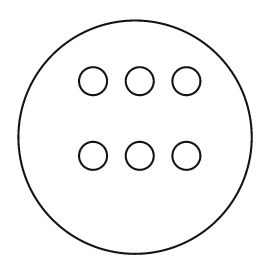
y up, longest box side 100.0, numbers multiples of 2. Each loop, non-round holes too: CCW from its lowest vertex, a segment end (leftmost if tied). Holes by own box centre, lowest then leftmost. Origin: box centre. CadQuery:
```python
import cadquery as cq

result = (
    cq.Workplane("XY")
    .moveTo(0.0, 0.0)
    .circle(50.0)
    .moveTo(-18.0, -8.0)
    .circle(6.0)
    .moveTo(2.0, -8.0)
    .circle(6.0)
    .moveTo(22.0, -8.0)
    .circle(6.0)
    .moveTo(-18.0, 24.0)
    .circle(6.0)
    .moveTo(2.0, 24.0)
    .circle(6.0)
    .moveTo(22.0, 24.0)
    .circle(6.0)
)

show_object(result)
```